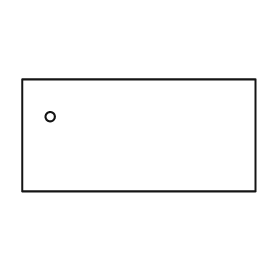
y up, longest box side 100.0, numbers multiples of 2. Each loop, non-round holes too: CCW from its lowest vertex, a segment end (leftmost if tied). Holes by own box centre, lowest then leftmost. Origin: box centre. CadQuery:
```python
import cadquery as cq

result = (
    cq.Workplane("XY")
    .moveTo(-50.0, -24.0)
    .lineTo(50.0, -24.0)
    .lineTo(50.0, 24.0)
    .lineTo(-50.0, 24.0)
    .close()
    .moveTo(-38.0, 8.0)
    .circle(2.0)
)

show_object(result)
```